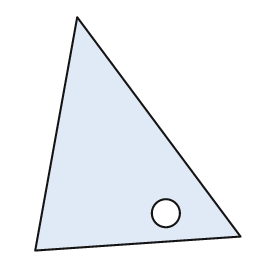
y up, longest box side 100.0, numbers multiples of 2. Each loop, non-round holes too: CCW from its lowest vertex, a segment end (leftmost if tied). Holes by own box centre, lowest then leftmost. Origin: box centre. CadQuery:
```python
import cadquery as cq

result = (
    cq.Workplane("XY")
    .moveTo(-44.0, -50.0)
    .lineTo(44.0, -44.0)
    .lineTo(-26.0, 50.0)
    .close()
    .moveTo(12.0, -34.0)
    .circle(6.0)
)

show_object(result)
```